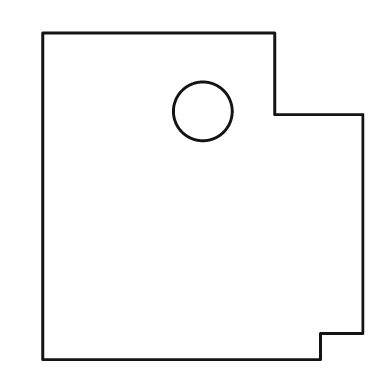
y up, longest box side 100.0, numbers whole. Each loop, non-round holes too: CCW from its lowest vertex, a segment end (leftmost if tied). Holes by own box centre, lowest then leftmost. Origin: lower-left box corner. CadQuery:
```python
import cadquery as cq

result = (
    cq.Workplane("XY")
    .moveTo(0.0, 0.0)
    .lineTo(85.0, 0.0)
    .lineTo(85.0, 8.0)
    .lineTo(98.0, 8.0)
    .lineTo(98.0, 75.0)
    .lineTo(71.0, 75.0)
    .lineTo(71.0, 100.0)
    .lineTo(0.0, 100.0)
    .close()
    .moveTo(49.0, 76.0)
    .circle(9.0)
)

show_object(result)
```